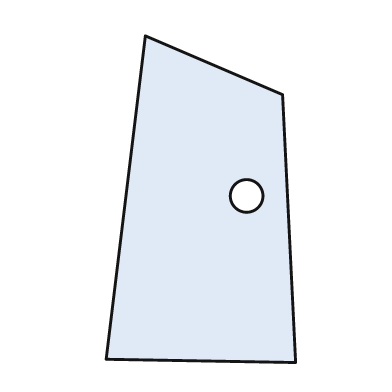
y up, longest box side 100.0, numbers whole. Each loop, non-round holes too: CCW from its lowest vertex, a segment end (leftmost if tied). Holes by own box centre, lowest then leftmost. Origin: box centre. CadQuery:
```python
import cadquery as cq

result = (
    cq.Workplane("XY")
    .moveTo(29.0, -50.0)
    .lineTo(25.0, 32.0)
    .lineTo(-17.0, 50.0)
    .lineTo(-29.0, -49.0)
    .close()
    .moveTo(14.0, 1.0)
    .circle(5.0)
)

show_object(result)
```